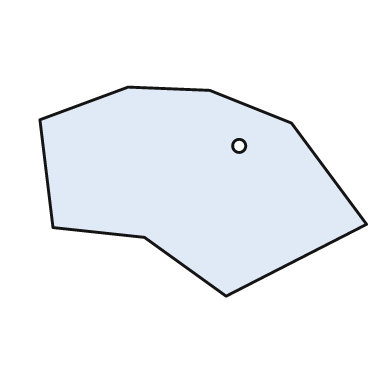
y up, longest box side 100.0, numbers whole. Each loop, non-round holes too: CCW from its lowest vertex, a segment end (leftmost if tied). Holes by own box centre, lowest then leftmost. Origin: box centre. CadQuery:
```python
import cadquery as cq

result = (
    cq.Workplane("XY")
    .moveTo(7.0, -32.0)
    .lineTo(50.0, -10.0)
    .lineTo(27.0, 21.0)
    .lineTo(2.0, 31.0)
    .lineTo(-23.0, 32.0)
    .lineTo(-50.0, 22.0)
    .lineTo(-46.0, -11.0)
    .lineTo(-18.0, -14.0)
    .close()
    .moveTo(11.0, 14.0)
    .circle(2.0)
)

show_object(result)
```